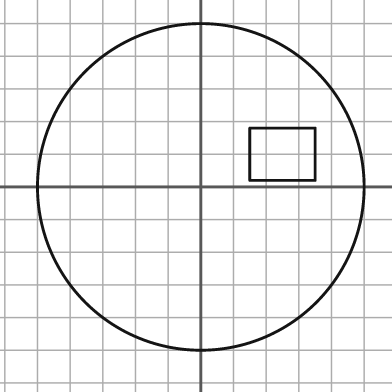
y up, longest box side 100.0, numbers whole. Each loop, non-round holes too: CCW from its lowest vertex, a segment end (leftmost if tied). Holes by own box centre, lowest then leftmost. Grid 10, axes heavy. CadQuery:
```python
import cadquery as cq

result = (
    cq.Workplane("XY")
    .moveTo(0.0, 0.0)
    .circle(50.0)
    .moveTo(15.0, 2.0)
    .lineTo(35.0, 2.0)
    .lineTo(35.0, 18.0)
    .lineTo(15.0, 18.0)
    .close()
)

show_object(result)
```